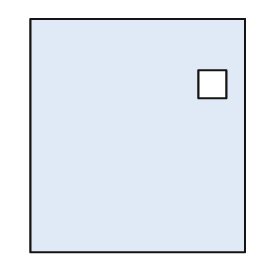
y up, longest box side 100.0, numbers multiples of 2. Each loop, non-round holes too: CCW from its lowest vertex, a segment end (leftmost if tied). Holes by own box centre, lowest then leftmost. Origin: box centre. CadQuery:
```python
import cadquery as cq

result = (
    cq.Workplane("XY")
    .moveTo(-46.0, -50.0)
    .lineTo(46.0, -50.0)
    .lineTo(46.0, 50.0)
    .lineTo(-46.0, 50.0)
    .close()
    .moveTo(26.0, 16.0)
    .lineTo(38.0, 16.0)
    .lineTo(38.0, 28.0)
    .lineTo(26.0, 28.0)
    .close()
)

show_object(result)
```